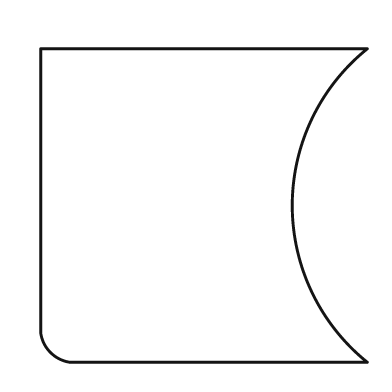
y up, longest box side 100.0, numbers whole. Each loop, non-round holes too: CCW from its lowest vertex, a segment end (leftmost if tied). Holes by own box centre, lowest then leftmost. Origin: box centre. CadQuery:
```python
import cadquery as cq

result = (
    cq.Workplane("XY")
    .moveTo(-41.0, -48.0)
    .lineTo(50.0, -48.0)
    .threePointArc((27.0, 0.0), (50.0, 48.0))
    .lineTo(-50.0, 48.0)
    .lineTo(-50.0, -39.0)
    .threePointArc((-47.0, -45.0), (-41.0, -48.0))
    .close()
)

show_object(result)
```